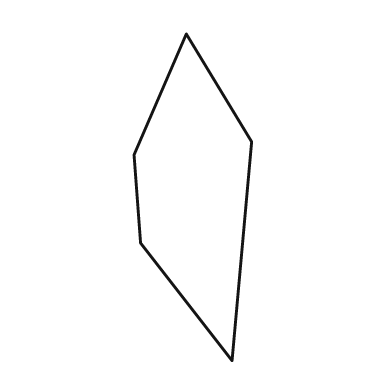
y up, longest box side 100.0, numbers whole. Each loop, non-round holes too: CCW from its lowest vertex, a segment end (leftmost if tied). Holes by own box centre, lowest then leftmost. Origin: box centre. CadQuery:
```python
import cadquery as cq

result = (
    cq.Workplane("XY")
    .moveTo(12.0, -50.0)
    .lineTo(18.0, 17.0)
    .lineTo(-2.0, 50.0)
    .lineTo(-18.0, 13.0)
    .lineTo(-16.0, -14.0)
    .close()
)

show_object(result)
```